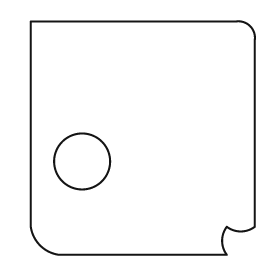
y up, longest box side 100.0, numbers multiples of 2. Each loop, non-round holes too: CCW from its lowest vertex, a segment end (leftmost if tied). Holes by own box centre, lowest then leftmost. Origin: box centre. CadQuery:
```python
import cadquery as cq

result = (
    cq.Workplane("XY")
    .moveTo(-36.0, -50.0)
    .lineTo(36.0, -50.0)
    .threePointArc((34.0, -44.0), (36.0, -38.0))
    .threePointArc((42.0, -40.0), (48.0, -38.0))
    .lineTo(48.0, 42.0)
    .threePointArc((46.0, 48.0), (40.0, 50.0))
    .lineTo(-48.0, 50.0)
    .lineTo(-48.0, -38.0)
    .threePointArc((-44.0, -46.0), (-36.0, -50.0))
    .close()
    .moveTo(-26.0, -10.0)
    .circle(12.0)
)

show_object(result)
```